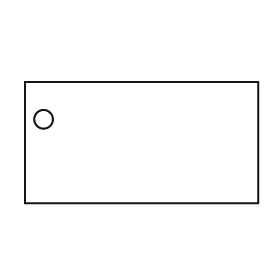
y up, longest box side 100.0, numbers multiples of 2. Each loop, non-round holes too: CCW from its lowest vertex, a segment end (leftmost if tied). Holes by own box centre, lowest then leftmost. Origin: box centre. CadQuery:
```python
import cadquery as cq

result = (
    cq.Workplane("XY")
    .moveTo(-50.0, -26.0)
    .lineTo(50.0, -26.0)
    .lineTo(50.0, 26.0)
    .lineTo(-50.0, 26.0)
    .close()
    .moveTo(-42.0, 10.0)
    .circle(4.0)
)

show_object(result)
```